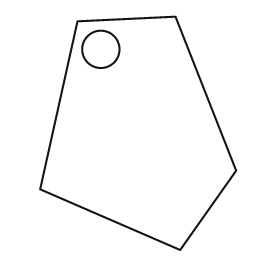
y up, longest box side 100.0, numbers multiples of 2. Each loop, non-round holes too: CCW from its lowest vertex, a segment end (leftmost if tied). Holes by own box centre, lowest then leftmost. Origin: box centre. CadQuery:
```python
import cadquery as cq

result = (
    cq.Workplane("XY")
    .moveTo(18.0, -50.0)
    .lineTo(42.0, -16.0)
    .lineTo(16.0, 50.0)
    .lineTo(-26.0, 48.0)
    .lineTo(-42.0, -24.0)
    .close()
    .moveTo(-16.0, 36.0)
    .circle(8.0)
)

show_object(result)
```